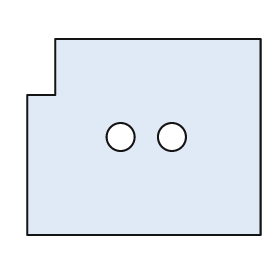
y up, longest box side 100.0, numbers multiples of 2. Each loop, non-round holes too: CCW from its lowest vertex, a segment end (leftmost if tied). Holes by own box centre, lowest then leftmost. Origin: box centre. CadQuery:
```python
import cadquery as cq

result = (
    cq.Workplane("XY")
    .moveTo(-50.0, -42.0)
    .lineTo(50.0, -42.0)
    .lineTo(50.0, 42.0)
    .lineTo(-38.0, 42.0)
    .lineTo(-38.0, 18.0)
    .lineTo(-50.0, 18.0)
    .close()
    .moveTo(-10.0, 0.0)
    .circle(6.0)
    .moveTo(12.0, 0.0)
    .circle(6.0)
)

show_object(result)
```